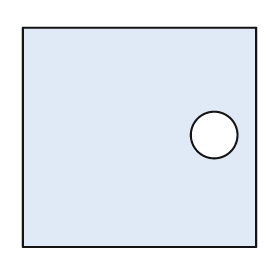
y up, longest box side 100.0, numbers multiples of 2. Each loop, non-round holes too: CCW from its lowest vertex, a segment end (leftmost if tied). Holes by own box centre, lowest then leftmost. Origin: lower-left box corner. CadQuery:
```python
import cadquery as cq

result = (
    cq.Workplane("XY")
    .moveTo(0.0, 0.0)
    .lineTo(100.0, 0.0)
    .lineTo(100.0, 94.0)
    .lineTo(0.0, 94.0)
    .close()
    .moveTo(82.0, 48.0)
    .circle(10.0)
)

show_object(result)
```